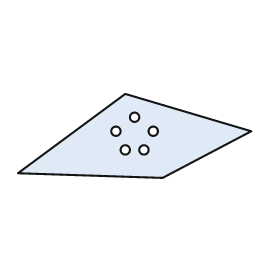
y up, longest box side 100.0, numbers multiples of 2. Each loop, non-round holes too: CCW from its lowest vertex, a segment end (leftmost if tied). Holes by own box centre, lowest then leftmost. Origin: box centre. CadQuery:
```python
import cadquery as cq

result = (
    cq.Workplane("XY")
    .moveTo(12.0, -18.0)
    .lineTo(50.0, 2.0)
    .lineTo(-4.0, 18.0)
    .lineTo(-50.0, -16.0)
    .close()
    .moveTo(-4.0, -6.0)
    .circle(2.0)
    .moveTo(4.0, -6.0)
    .circle(2.0)
    .moveTo(-8.0, 2.0)
    .circle(2.0)
    .moveTo(8.0, 2.0)
    .circle(2.0)
    .moveTo(0.0, 8.0)
    .circle(2.0)
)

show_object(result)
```